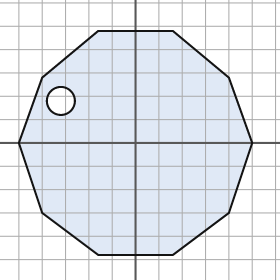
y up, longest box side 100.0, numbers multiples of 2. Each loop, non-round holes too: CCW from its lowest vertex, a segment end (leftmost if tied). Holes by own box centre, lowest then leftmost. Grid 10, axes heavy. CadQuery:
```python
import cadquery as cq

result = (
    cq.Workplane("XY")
    .moveTo(-16.0, -48.0)
    .lineTo(16.0, -48.0)
    .lineTo(40.0, -30.0)
    .lineTo(50.0, 0.0)
    .lineTo(40.0, 28.0)
    .lineTo(16.0, 48.0)
    .lineTo(-16.0, 48.0)
    .lineTo(-40.0, 28.0)
    .lineTo(-50.0, 0.0)
    .lineTo(-40.0, -30.0)
    .close()
    .moveTo(-32.0, 18.0)
    .circle(6.0)
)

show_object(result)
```